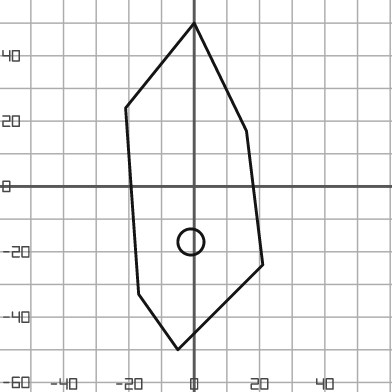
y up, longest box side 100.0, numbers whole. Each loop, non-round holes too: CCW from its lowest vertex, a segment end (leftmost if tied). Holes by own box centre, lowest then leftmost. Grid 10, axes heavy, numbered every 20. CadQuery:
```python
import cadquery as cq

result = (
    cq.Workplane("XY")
    .moveTo(-5.0, -50.0)
    .lineTo(21.0, -24.0)
    .lineTo(16.0, 17.0)
    .lineTo(0.0, 50.0)
    .lineTo(-21.0, 24.0)
    .lineTo(-17.0, -33.0)
    .close()
    .moveTo(-1.0, -17.0)
    .circle(4.0)
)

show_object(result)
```